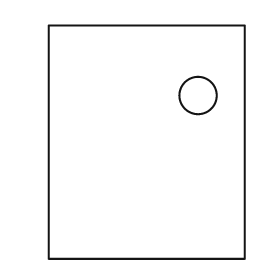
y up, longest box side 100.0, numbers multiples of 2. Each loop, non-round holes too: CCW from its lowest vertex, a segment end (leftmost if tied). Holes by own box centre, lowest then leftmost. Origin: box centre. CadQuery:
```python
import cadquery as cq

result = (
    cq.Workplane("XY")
    .moveTo(-42.0, -50.0)
    .lineTo(42.0, -50.0)
    .lineTo(42.0, 50.0)
    .lineTo(-42.0, 50.0)
    .close()
    .moveTo(22.0, 20.0)
    .circle(8.0)
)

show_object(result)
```